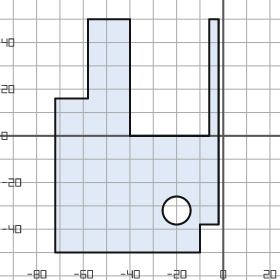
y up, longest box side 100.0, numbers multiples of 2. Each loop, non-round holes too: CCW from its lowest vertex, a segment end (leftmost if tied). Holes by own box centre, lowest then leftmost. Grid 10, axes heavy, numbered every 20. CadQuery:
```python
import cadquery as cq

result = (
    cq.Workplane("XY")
    .moveTo(-72.0, -50.0)
    .lineTo(-10.0, -50.0)
    .lineTo(-10.0, -38.0)
    .lineTo(-2.0, -38.0)
    .lineTo(-2.0, 50.0)
    .lineTo(-6.0, 50.0)
    .lineTo(-6.0, 0.0)
    .lineTo(-40.0, 0.0)
    .lineTo(-40.0, 50.0)
    .lineTo(-58.0, 50.0)
    .lineTo(-58.0, 16.0)
    .lineTo(-72.0, 16.0)
    .close()
    .moveTo(-20.0, -32.0)
    .circle(6.0)
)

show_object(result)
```